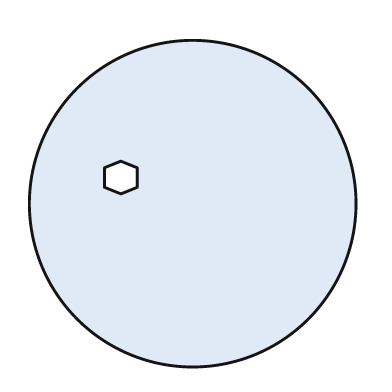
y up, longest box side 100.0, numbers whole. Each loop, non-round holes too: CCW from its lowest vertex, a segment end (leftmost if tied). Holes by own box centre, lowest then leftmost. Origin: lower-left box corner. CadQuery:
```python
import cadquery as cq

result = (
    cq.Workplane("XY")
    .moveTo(50.0, 50.0)
    .circle(50.0)
    .moveTo(28.0, 53.0)
    .lineTo(33.0, 55.0)
    .lineTo(33.0, 61.0)
    .lineTo(28.0, 63.0)
    .lineTo(23.0, 61.0)
    .lineTo(23.0, 55.0)
    .close()
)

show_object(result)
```